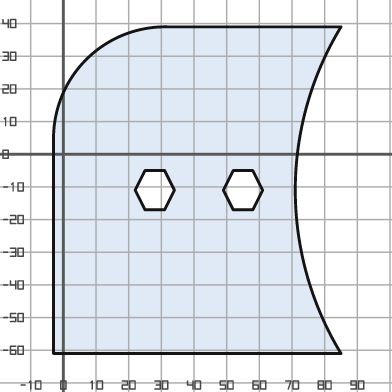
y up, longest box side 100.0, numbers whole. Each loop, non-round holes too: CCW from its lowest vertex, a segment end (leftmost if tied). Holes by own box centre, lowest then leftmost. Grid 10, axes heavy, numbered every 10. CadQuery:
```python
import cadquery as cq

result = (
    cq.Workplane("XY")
    .moveTo(-3.0, -61.0)
    .lineTo(85.0, -61.0)
    .threePointArc((71.0, -11.0), (85.0, 39.0))
    .lineTo(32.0, 39.0)
    .threePointArc((7.0, 29.0), (-3.0, 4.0))
    .close()
    .moveTo(25.0, -17.0)
    .lineTo(31.0, -17.0)
    .lineTo(34.0, -11.0)
    .lineTo(31.0, -5.0)
    .lineTo(25.0, -5.0)
    .lineTo(22.0, -11.0)
    .close()
    .moveTo(52.0, -17.0)
    .lineTo(58.0, -17.0)
    .lineTo(61.0, -11.0)
    .lineTo(58.0, -5.0)
    .lineTo(52.0, -5.0)
    .lineTo(49.0, -11.0)
    .close()
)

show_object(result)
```